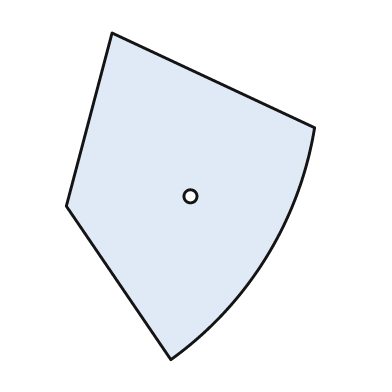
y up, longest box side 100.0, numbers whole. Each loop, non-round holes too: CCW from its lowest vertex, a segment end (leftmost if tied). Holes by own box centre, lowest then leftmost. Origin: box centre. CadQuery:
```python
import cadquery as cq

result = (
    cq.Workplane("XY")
    .moveTo(-6.0, -50.0)
    .threePointArc((23.0, -19.0), (38.0, 21.0))
    .lineTo(-24.0, 50.0)
    .lineTo(-38.0, -3.0)
    .close()
    .moveTo(0.0, 0.0)
    .circle(2.0)
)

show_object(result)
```